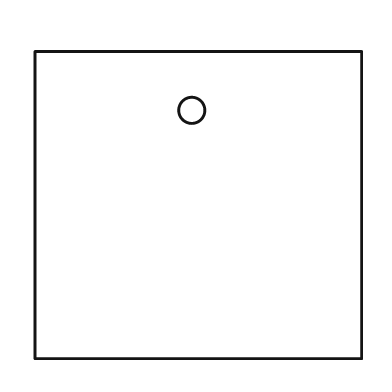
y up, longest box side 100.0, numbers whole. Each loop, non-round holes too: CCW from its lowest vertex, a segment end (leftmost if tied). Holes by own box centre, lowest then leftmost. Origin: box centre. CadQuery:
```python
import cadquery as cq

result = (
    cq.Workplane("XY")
    .moveTo(-50.0, -47.0)
    .lineTo(50.0, -47.0)
    .lineTo(50.0, 47.0)
    .lineTo(-50.0, 47.0)
    .close()
    .moveTo(-2.0, 29.0)
    .circle(4.0)
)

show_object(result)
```